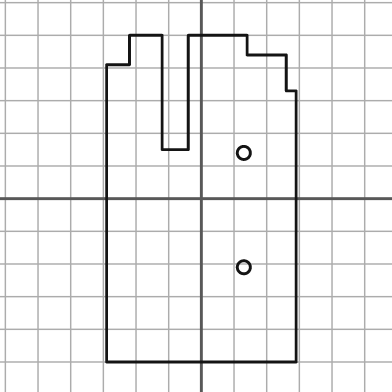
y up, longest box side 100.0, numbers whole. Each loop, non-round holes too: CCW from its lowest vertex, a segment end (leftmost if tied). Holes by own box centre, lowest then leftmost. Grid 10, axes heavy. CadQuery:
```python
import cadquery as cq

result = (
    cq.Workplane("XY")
    .moveTo(-29.0, -50.0)
    .lineTo(29.0, -50.0)
    .lineTo(29.0, 33.0)
    .lineTo(26.0, 33.0)
    .lineTo(26.0, 44.0)
    .lineTo(14.0, 44.0)
    .lineTo(14.0, 50.0)
    .lineTo(-4.0, 50.0)
    .lineTo(-4.0, 15.0)
    .lineTo(-12.0, 15.0)
    .lineTo(-12.0, 50.0)
    .lineTo(-22.0, 50.0)
    .lineTo(-22.0, 41.0)
    .lineTo(-29.0, 41.0)
    .close()
    .moveTo(13.0, -21.0)
    .circle(2.0)
    .moveTo(13.0, 14.0)
    .circle(2.0)
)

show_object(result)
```